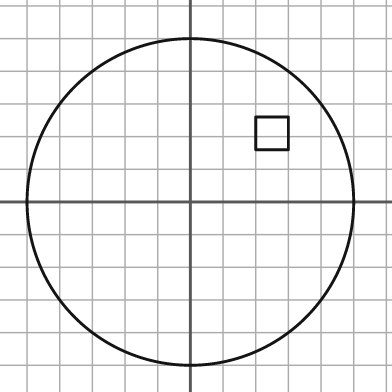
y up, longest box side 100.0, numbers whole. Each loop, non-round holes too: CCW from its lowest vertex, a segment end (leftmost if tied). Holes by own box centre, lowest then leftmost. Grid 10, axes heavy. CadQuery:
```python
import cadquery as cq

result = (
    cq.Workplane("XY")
    .moveTo(0.0, 0.0)
    .circle(50.0)
    .moveTo(20.0, 16.0)
    .lineTo(30.0, 16.0)
    .lineTo(30.0, 26.0)
    .lineTo(20.0, 26.0)
    .close()
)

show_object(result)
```